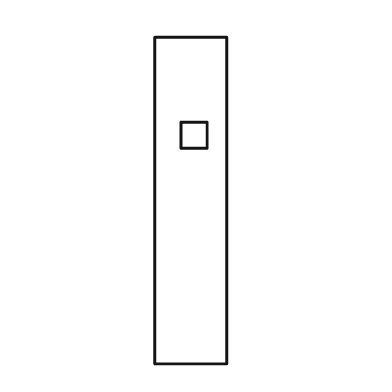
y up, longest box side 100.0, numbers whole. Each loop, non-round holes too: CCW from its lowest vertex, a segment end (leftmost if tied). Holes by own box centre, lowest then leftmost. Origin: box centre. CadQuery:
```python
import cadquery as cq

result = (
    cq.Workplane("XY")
    .moveTo(-11.0, -50.0)
    .lineTo(11.0, -50.0)
    .lineTo(11.0, 50.0)
    .lineTo(-11.0, 50.0)
    .close()
    .moveTo(-3.0, 16.0)
    .lineTo(5.0, 16.0)
    .lineTo(5.0, 24.0)
    .lineTo(-3.0, 24.0)
    .close()
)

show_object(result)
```